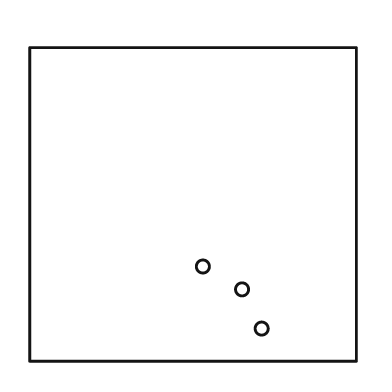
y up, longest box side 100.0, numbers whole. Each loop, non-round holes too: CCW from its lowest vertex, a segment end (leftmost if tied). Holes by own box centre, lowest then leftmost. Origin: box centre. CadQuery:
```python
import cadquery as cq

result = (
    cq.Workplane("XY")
    .moveTo(-50.0, -48.0)
    .lineTo(50.0, -48.0)
    .lineTo(50.0, 48.0)
    .lineTo(-50.0, 48.0)
    .close()
    .moveTo(21.0, -38.0)
    .circle(2.0)
    .moveTo(15.0, -26.0)
    .circle(2.0)
    .moveTo(3.0, -19.0)
    .circle(2.0)
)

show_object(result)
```